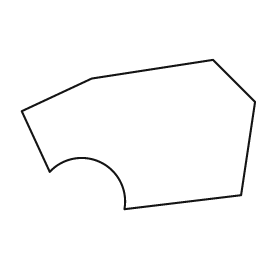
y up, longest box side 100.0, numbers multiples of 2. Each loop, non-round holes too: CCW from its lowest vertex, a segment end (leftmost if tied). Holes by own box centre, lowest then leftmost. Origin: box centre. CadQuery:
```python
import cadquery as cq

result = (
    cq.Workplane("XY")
    .moveTo(-6.0, -32.0)
    .lineTo(44.0, -26.0)
    .lineTo(50.0, 14.0)
    .lineTo(32.0, 32.0)
    .lineTo(-20.0, 24.0)
    .lineTo(-50.0, 10.0)
    .lineTo(-38.0, -16.0)
    .threePointArc((-16.0, -12.0), (-6.0, -32.0))
    .close()
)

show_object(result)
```